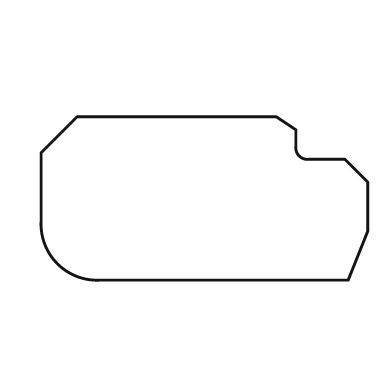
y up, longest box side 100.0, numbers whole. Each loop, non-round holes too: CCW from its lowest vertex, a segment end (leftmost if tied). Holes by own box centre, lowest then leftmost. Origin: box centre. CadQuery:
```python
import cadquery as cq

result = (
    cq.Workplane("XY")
    .moveTo(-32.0, -25.0)
    .lineTo(44.0, -25.0)
    .lineTo(50.0, -10.0)
    .lineTo(50.0, 5.0)
    .lineTo(43.0, 12.0)
    .lineTo(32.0, 12.0)
    .threePointArc((29.0, 13.0), (28.0, 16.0))
    .lineTo(28.0, 21.0)
    .lineTo(22.0, 25.0)
    .lineTo(-39.0, 25.0)
    .lineTo(-50.0, 14.0)
    .lineTo(-50.0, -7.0)
    .threePointArc((-45.0, -20.0), (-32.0, -25.0))
    .close()
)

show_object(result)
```